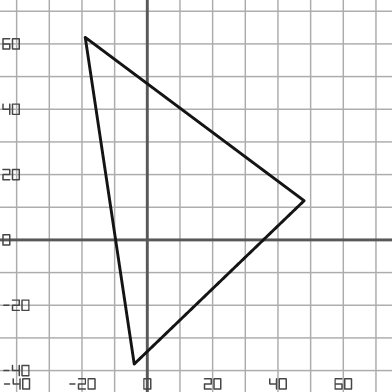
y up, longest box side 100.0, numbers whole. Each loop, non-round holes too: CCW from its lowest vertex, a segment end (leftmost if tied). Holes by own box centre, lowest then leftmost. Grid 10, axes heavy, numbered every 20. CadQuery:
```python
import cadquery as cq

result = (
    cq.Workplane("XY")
    .moveTo(-4.0, -38.0)
    .lineTo(48.0, 12.0)
    .lineTo(-19.0, 62.0)
    .close()
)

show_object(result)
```